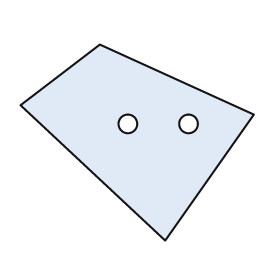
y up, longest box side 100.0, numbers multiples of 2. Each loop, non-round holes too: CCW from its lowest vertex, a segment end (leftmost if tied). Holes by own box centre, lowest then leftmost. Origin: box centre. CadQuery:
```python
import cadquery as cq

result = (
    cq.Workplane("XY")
    .moveTo(12.0, -42.0)
    .lineTo(50.0, 12.0)
    .lineTo(-16.0, 42.0)
    .lineTo(-50.0, 16.0)
    .close()
    .moveTo(-4.0, 8.0)
    .circle(4.0)
    .moveTo(22.0, 8.0)
    .circle(4.0)
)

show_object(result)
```